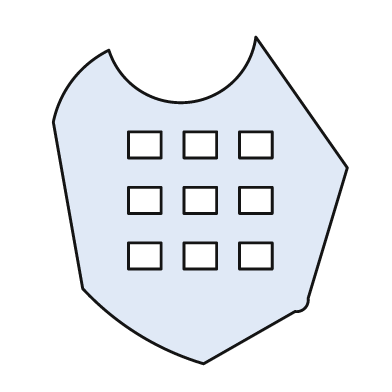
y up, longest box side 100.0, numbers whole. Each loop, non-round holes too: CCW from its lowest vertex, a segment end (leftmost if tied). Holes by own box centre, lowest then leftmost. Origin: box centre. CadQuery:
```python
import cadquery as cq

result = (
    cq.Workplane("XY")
    .moveTo(1.0, -50.0)
    .lineTo(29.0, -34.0)
    .threePointArc((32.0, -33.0), (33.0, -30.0))
    .lineTo(45.0, 10.0)
    .lineTo(17.0, 50.0)
    .threePointArc((-4.0, 30.0), (-28.0, 46.0))
    .threePointArc((-39.0, 37.0), (-45.0, 24.0))
    .lineTo(-36.0, -27.0)
    .threePointArc((-19.0, -41.0), (1.0, -50.0))
    .close()
    .moveTo(-22.0, -21.0)
    .lineTo(-12.0, -21.0)
    .lineTo(-12.0, -13.0)
    .lineTo(-22.0, -13.0)
    .close()
    .moveTo(-5.0, -21.0)
    .lineTo(5.0, -21.0)
    .lineTo(5.0, -13.0)
    .lineTo(-5.0, -13.0)
    .close()
    .moveTo(12.0, -21.0)
    .lineTo(22.0, -21.0)
    .lineTo(22.0, -13.0)
    .lineTo(12.0, -13.0)
    .close()
    .moveTo(-22.0, -4.0)
    .lineTo(-12.0, -4.0)
    .lineTo(-12.0, 4.0)
    .lineTo(-22.0, 4.0)
    .close()
    .moveTo(-5.0, -4.0)
    .lineTo(5.0, -4.0)
    .lineTo(5.0, 4.0)
    .lineTo(-5.0, 4.0)
    .close()
    .moveTo(12.0, -4.0)
    .lineTo(22.0, -4.0)
    .lineTo(22.0, 4.0)
    .lineTo(12.0, 4.0)
    .close()
    .moveTo(-22.0, 13.0)
    .lineTo(-12.0, 13.0)
    .lineTo(-12.0, 21.0)
    .lineTo(-22.0, 21.0)
    .close()
    .moveTo(-5.0, 13.0)
    .lineTo(5.0, 13.0)
    .lineTo(5.0, 21.0)
    .lineTo(-5.0, 21.0)
    .close()
    .moveTo(12.0, 13.0)
    .lineTo(22.0, 13.0)
    .lineTo(22.0, 21.0)
    .lineTo(12.0, 21.0)
    .close()
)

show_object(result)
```